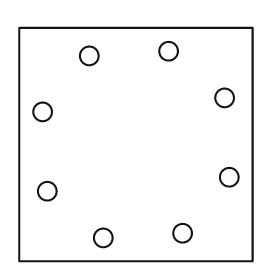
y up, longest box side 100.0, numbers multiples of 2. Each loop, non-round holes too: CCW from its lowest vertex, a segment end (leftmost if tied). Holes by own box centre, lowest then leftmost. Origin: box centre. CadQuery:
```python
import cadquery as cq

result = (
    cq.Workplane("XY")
    .moveTo(-50.0, -50.0)
    .lineTo(50.0, -50.0)
    .lineTo(50.0, 50.0)
    .lineTo(-50.0, 50.0)
    .close()
    .moveTo(-14.0, -40.0)
    .circle(4.0)
    .moveTo(20.0, -38.0)
    .circle(4.0)
    .moveTo(-38.0, -20.0)
    .circle(4.0)
    .moveTo(40.0, -14.0)
    .circle(4.0)
    .moveTo(-40.0, 14.0)
    .circle(4.0)
    .moveTo(38.0, 20.0)
    .circle(4.0)
    .moveTo(-20.0, 38.0)
    .circle(4.0)
    .moveTo(14.0, 40.0)
    .circle(4.0)
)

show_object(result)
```